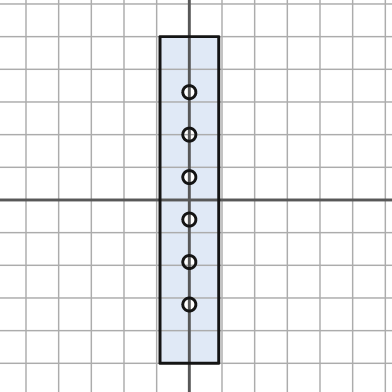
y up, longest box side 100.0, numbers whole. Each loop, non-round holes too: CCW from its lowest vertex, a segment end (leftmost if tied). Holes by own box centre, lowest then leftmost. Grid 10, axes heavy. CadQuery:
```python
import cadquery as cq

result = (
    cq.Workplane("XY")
    .moveTo(-9.0, -50.0)
    .lineTo(9.0, -50.0)
    .lineTo(9.0, 50.0)
    .lineTo(-9.0, 50.0)
    .close()
    .moveTo(0.0, -32.0)
    .circle(2.0)
    .moveTo(0.0, -19.0)
    .circle(2.0)
    .moveTo(0.0, -6.0)
    .circle(2.0)
    .moveTo(0.0, 7.0)
    .circle(2.0)
    .moveTo(0.0, 20.0)
    .circle(2.0)
    .moveTo(0.0, 33.0)
    .circle(2.0)
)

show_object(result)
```